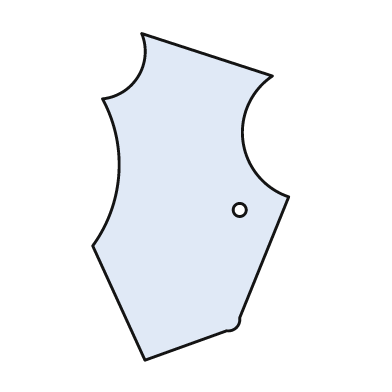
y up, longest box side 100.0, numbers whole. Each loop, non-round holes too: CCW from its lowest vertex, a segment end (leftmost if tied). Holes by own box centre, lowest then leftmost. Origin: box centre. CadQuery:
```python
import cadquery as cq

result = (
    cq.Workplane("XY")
    .moveTo(-14.0, -50.0)
    .lineTo(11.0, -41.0)
    .threePointArc((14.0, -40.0), (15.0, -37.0))
    .lineTo(30.0, 0.0)
    .threePointArc((16.0, 17.0), (25.0, 37.0))
    .lineTo(-15.0, 50.0)
    .threePointArc((-16.0, 37.0), (-27.0, 30.0))
    .threePointArc((-22.0, 7.0), (-30.0, -15.0))
    .close()
    .moveTo(15.0, -4.0)
    .circle(2.0)
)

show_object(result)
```